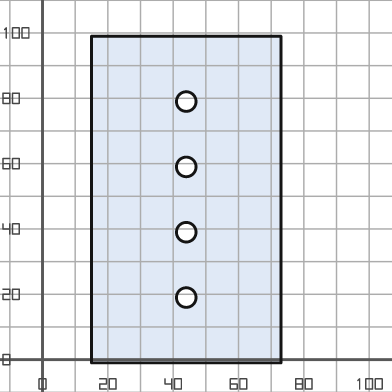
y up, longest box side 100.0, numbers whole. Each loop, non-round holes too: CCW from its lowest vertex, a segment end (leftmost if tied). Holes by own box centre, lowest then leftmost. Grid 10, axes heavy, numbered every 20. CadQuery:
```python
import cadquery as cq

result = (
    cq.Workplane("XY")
    .moveTo(15.0, -1.0)
    .lineTo(73.0, -1.0)
    .lineTo(73.0, 99.0)
    .lineTo(15.0, 99.0)
    .close()
    .moveTo(44.0, 19.0)
    .circle(3.0)
    .moveTo(44.0, 39.0)
    .circle(3.0)
    .moveTo(44.0, 59.0)
    .circle(3.0)
    .moveTo(44.0, 79.0)
    .circle(3.0)
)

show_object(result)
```